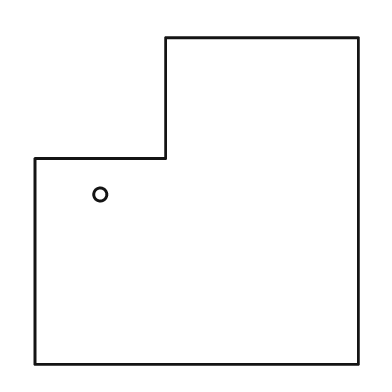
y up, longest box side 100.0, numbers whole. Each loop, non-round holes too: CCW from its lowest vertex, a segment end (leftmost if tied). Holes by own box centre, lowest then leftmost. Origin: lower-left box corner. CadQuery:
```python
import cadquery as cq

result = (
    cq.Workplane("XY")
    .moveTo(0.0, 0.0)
    .lineTo(99.0, 0.0)
    .lineTo(99.0, 100.0)
    .lineTo(40.0, 100.0)
    .lineTo(40.0, 63.0)
    .lineTo(0.0, 63.0)
    .close()
    .moveTo(20.0, 52.0)
    .circle(2.0)
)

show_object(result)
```